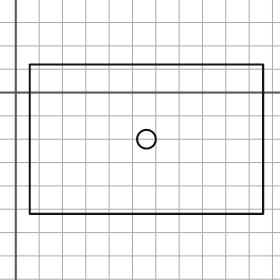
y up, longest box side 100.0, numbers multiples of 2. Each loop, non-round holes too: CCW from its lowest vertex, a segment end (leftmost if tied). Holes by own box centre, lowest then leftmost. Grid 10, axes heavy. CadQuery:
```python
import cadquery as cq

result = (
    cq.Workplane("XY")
    .moveTo(6.0, -52.0)
    .lineTo(106.0, -52.0)
    .lineTo(106.0, 12.0)
    .lineTo(6.0, 12.0)
    .close()
    .moveTo(56.0, -20.0)
    .circle(4.0)
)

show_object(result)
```